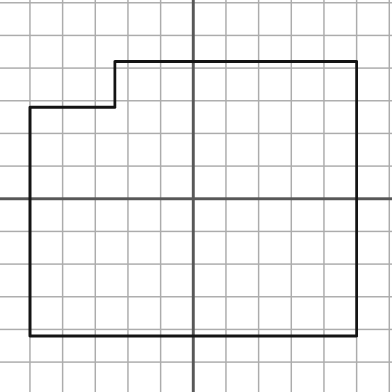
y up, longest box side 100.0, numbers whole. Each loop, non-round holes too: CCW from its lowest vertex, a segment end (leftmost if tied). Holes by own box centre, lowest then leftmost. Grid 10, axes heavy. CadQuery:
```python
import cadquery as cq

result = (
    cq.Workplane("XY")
    .moveTo(-50.0, -42.0)
    .lineTo(50.0, -42.0)
    .lineTo(50.0, 42.0)
    .lineTo(-24.0, 42.0)
    .lineTo(-24.0, 28.0)
    .lineTo(-50.0, 28.0)
    .close()
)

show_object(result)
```